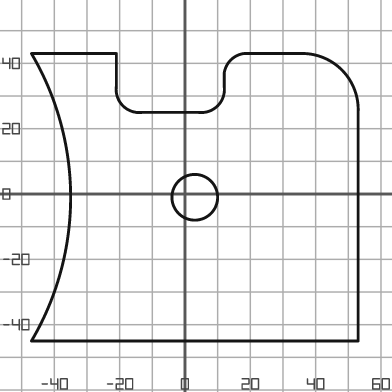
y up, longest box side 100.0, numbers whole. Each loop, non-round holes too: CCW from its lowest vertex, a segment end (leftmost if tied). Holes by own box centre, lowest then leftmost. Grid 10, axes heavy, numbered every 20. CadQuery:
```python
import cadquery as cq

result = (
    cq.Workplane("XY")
    .moveTo(-47.0, -45.0)
    .lineTo(53.0, -45.0)
    .lineTo(53.0, 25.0)
    .threePointArc((48.0, 38.0), (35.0, 43.0))
    .lineTo(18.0, 43.0)
    .threePointArc((14.0, 41.0), (12.0, 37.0))
    .lineTo(12.0, 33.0)
    .threePointArc((10.0, 27.0), (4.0, 25.0))
    .lineTo(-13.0, 25.0)
    .threePointArc((-19.0, 27.0), (-21.0, 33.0))
    .lineTo(-21.0, 43.0)
    .lineTo(-47.0, 43.0)
    .threePointArc((-35.0, -1.0), (-47.0, -45.0))
    .close()
    .moveTo(3.0, -1.0)
    .circle(7.0)
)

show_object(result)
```